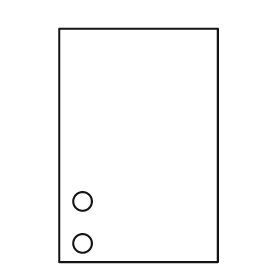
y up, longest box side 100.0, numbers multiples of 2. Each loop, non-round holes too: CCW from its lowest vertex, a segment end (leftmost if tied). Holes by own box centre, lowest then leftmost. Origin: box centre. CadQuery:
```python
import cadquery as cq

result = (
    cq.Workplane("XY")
    .moveTo(-34.0, -50.0)
    .lineTo(34.0, -50.0)
    .lineTo(34.0, 50.0)
    .lineTo(-34.0, 50.0)
    .close()
    .moveTo(-24.0, -42.0)
    .circle(4.0)
    .moveTo(-24.0, -24.0)
    .circle(4.0)
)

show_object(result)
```